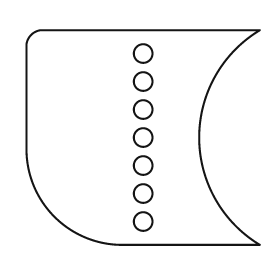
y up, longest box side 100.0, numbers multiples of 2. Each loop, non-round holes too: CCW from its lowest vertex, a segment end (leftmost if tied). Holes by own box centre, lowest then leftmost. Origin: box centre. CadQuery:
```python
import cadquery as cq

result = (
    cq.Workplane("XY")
    .moveTo(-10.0, -46.0)
    .lineTo(50.0, -46.0)
    .threePointArc((24.0, 0.0), (50.0, 46.0))
    .lineTo(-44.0, 46.0)
    .threePointArc((-48.0, 44.0), (-50.0, 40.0))
    .lineTo(-50.0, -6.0)
    .threePointArc((-38.0, -34.0), (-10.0, -46.0))
    .close()
    .moveTo(0.0, -36.0)
    .circle(4.0)
    .moveTo(0.0, -24.0)
    .circle(4.0)
    .moveTo(0.0, -12.0)
    .circle(4.0)
    .moveTo(0.0, 0.0)
    .circle(4.0)
    .moveTo(0.0, 12.0)
    .circle(4.0)
    .moveTo(0.0, 24.0)
    .circle(4.0)
    .moveTo(0.0, 36.0)
    .circle(4.0)
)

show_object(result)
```